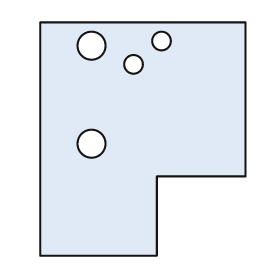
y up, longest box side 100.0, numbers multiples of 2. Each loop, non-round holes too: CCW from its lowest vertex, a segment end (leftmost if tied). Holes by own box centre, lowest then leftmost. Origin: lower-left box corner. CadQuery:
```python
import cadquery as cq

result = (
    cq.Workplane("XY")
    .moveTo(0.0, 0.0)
    .lineTo(50.0, 0.0)
    .lineTo(50.0, 34.0)
    .lineTo(88.0, 34.0)
    .lineTo(88.0, 100.0)
    .lineTo(0.0, 100.0)
    .close()
    .moveTo(22.0, 48.0)
    .circle(6.0)
    .moveTo(40.0, 82.0)
    .circle(4.0)
    .moveTo(22.0, 90.0)
    .circle(6.0)
    .moveTo(52.0, 92.0)
    .circle(4.0)
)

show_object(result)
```